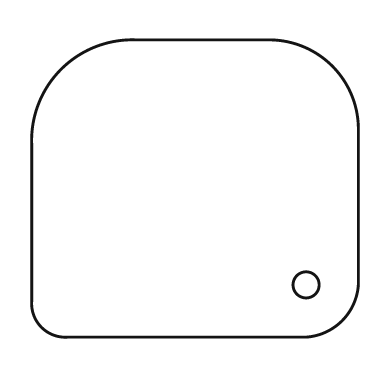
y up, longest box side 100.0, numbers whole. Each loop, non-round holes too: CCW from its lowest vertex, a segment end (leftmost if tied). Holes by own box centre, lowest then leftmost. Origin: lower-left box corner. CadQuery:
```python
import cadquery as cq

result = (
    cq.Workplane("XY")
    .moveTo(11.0, 0.0)
    .lineTo(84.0, 0.0)
    .threePointArc((95.0, 5.0), (100.0, 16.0))
    .lineTo(100.0, 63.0)
    .threePointArc((92.0, 83.0), (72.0, 91.0))
    .lineTo(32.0, 91.0)
    .threePointArc((9.0, 82.0), (0.0, 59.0))
    .lineTo(0.0, 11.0)
    .threePointArc((3.0, 3.0), (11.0, 0.0))
    .close()
    .moveTo(84.0, 16.0)
    .circle(4.0)
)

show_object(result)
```